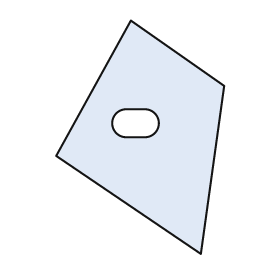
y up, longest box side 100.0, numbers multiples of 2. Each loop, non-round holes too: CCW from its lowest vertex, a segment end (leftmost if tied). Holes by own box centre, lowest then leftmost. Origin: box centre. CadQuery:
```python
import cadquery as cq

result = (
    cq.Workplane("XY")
    .moveTo(26.0, -50.0)
    .lineTo(36.0, 22.0)
    .lineTo(-4.0, 50.0)
    .lineTo(-36.0, -8.0)
    .close()
    .moveTo(-6.0, 0.0)
    .lineTo(2.0, 0.0)
    .threePointArc((8.0, 6.0), (2.0, 12.0))
    .lineTo(-6.0, 12.0)
    .threePointArc((-12.0, 6.0), (-6.0, 0.0))
    .close()
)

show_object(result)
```